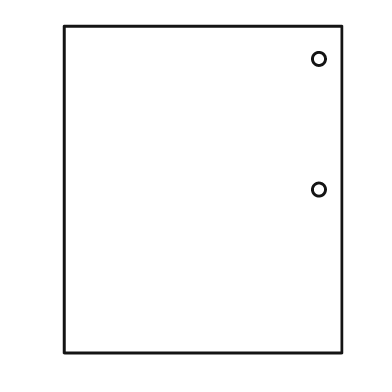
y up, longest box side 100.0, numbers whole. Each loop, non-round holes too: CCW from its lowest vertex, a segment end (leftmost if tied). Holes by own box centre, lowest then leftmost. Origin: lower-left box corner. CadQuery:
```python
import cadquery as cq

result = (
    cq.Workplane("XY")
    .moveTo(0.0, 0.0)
    .lineTo(85.0, 0.0)
    .lineTo(85.0, 100.0)
    .lineTo(0.0, 100.0)
    .close()
    .moveTo(78.0, 50.0)
    .circle(2.0)
    .moveTo(78.0, 90.0)
    .circle(2.0)
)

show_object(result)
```